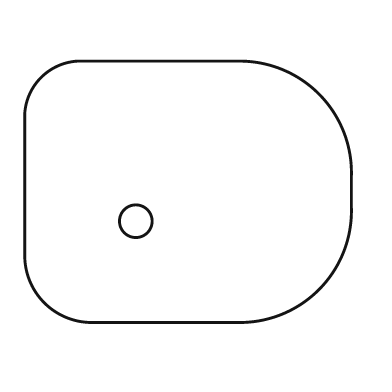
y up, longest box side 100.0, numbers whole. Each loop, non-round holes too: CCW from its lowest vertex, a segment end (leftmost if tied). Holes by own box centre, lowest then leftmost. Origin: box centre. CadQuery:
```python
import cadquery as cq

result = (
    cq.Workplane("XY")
    .moveTo(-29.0, -40.0)
    .lineTo(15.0, -40.0)
    .threePointArc((40.0, -30.0), (50.0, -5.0))
    .lineTo(50.0, 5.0)
    .threePointArc((40.0, 30.0), (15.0, 40.0))
    .lineTo(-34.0, 40.0)
    .threePointArc((-45.0, 35.0), (-50.0, 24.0))
    .lineTo(-50.0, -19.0)
    .threePointArc((-44.0, -34.0), (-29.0, -40.0))
    .close()
    .moveTo(-16.0, -9.0)
    .circle(5.0)
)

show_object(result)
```